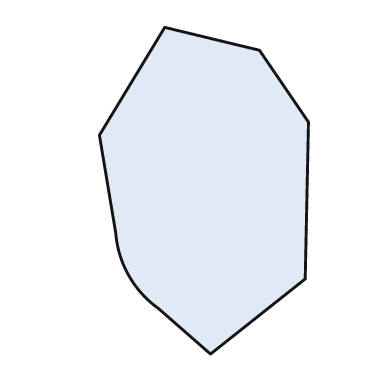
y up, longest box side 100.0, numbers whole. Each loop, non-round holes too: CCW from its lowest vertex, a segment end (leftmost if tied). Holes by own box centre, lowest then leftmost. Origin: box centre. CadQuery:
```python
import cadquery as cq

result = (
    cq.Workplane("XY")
    .moveTo(2.0, -50.0)
    .lineTo(31.0, -27.0)
    .lineTo(32.0, 21.0)
    .lineTo(17.0, 43.0)
    .lineTo(-12.0, 50.0)
    .lineTo(-32.0, 17.0)
    .lineTo(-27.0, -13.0)
    .threePointArc((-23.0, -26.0), (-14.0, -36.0))
    .close()
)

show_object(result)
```